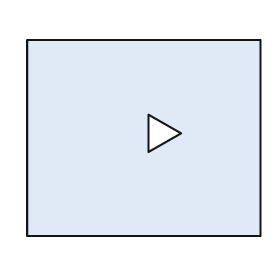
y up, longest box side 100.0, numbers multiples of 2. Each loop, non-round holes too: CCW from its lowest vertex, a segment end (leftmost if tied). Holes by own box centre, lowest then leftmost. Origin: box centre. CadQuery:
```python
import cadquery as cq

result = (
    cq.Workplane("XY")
    .moveTo(-50.0, -42.0)
    .lineTo(50.0, -42.0)
    .lineTo(50.0, 42.0)
    .lineTo(-50.0, 42.0)
    .close()
    .moveTo(2.0, -6.0)
    .lineTo(16.0, 2.0)
    .lineTo(2.0, 10.0)
    .close()
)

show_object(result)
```